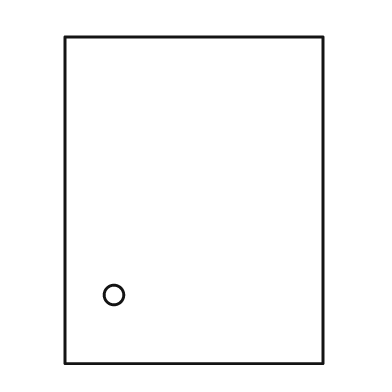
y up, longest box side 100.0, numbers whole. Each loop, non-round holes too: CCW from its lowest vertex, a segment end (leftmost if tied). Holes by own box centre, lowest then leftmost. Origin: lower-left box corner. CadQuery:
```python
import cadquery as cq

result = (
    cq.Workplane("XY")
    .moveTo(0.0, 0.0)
    .lineTo(79.0, 0.0)
    .lineTo(79.0, 100.0)
    .lineTo(0.0, 100.0)
    .close()
    .moveTo(15.0, 21.0)
    .circle(3.0)
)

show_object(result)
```